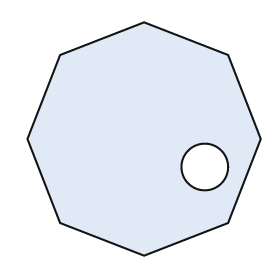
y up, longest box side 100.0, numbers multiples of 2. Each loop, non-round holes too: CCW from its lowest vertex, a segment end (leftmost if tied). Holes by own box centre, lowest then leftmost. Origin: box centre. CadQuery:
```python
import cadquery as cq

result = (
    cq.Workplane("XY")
    .moveTo(0.0, -50.0)
    .lineTo(36.0, -36.0)
    .lineTo(50.0, 0.0)
    .lineTo(36.0, 36.0)
    .lineTo(0.0, 50.0)
    .lineTo(-36.0, 36.0)
    .lineTo(-50.0, 0.0)
    .lineTo(-36.0, -36.0)
    .close()
    .moveTo(26.0, -12.0)
    .circle(10.0)
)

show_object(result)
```